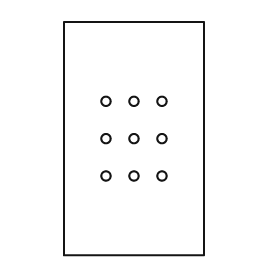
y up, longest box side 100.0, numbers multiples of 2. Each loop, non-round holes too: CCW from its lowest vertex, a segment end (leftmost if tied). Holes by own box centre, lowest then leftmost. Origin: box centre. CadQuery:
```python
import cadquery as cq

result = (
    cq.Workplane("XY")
    .moveTo(-30.0, -50.0)
    .lineTo(30.0, -50.0)
    .lineTo(30.0, 50.0)
    .lineTo(-30.0, 50.0)
    .close()
    .moveTo(-12.0, -16.0)
    .circle(2.0)
    .moveTo(0.0, -16.0)
    .circle(2.0)
    .moveTo(12.0, -16.0)
    .circle(2.0)
    .moveTo(-12.0, 0.0)
    .circle(2.0)
    .moveTo(0.0, 0.0)
    .circle(2.0)
    .moveTo(12.0, 0.0)
    .circle(2.0)
    .moveTo(-12.0, 16.0)
    .circle(2.0)
    .moveTo(0.0, 16.0)
    .circle(2.0)
    .moveTo(12.0, 16.0)
    .circle(2.0)
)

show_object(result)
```